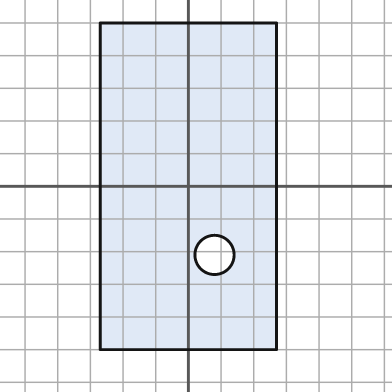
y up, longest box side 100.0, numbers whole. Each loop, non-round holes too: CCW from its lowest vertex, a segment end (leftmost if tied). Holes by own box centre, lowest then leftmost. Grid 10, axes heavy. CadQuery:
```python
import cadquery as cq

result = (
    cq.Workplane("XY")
    .moveTo(-27.0, -50.0)
    .lineTo(27.0, -50.0)
    .lineTo(27.0, 50.0)
    .lineTo(-27.0, 50.0)
    .close()
    .moveTo(8.0, -21.0)
    .circle(6.0)
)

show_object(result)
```